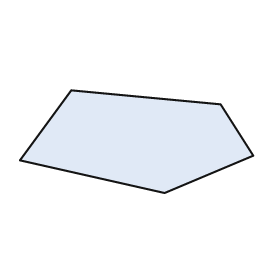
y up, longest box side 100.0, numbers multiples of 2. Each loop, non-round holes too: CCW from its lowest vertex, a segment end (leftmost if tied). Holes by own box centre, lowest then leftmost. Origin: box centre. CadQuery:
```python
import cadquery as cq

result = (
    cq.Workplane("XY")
    .moveTo(12.0, -22.0)
    .lineTo(50.0, -6.0)
    .lineTo(36.0, 16.0)
    .lineTo(-28.0, 22.0)
    .lineTo(-50.0, -8.0)
    .close()
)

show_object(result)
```